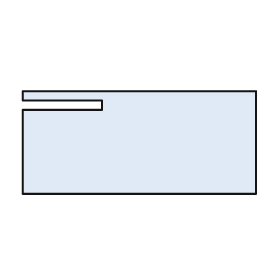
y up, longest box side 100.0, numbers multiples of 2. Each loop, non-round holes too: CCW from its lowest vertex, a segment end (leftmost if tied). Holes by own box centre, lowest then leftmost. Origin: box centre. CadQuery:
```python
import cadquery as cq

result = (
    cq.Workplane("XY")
    .moveTo(-50.0, -22.0)
    .lineTo(50.0, -22.0)
    .lineTo(50.0, 22.0)
    .lineTo(-50.0, 22.0)
    .lineTo(-50.0, 18.0)
    .lineTo(-16.0, 18.0)
    .lineTo(-16.0, 14.0)
    .lineTo(-50.0, 14.0)
    .close()
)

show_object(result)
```